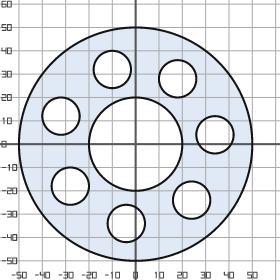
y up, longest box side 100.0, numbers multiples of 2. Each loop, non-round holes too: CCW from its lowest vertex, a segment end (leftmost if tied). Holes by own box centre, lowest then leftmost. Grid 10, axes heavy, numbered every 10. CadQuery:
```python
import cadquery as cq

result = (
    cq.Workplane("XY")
    .moveTo(0.0, 0.0)
    .circle(50.0)
    .moveTo(-4.0, -34.0)
    .circle(8.0)
    .moveTo(24.0, -24.0)
    .circle(8.0)
    .moveTo(-28.0, -18.0)
    .circle(8.0)
    .moveTo(0.0, 0.0)
    .circle(20.0)
    .moveTo(34.0, 4.0)
    .circle(8.0)
    .moveTo(-32.0, 12.0)
    .circle(8.0)
    .moveTo(18.0, 28.0)
    .circle(8.0)
    .moveTo(-10.0, 32.0)
    .circle(8.0)
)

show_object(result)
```